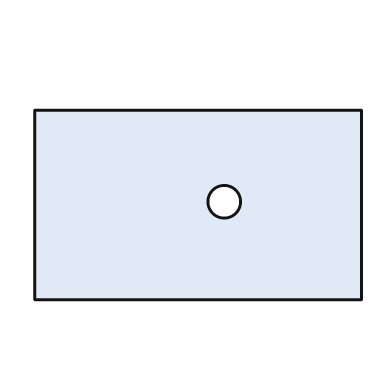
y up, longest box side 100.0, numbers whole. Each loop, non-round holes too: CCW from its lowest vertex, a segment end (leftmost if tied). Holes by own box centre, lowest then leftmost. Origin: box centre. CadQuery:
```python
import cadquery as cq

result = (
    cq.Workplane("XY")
    .moveTo(-50.0, -29.0)
    .lineTo(50.0, -29.0)
    .lineTo(50.0, 29.0)
    .lineTo(-50.0, 29.0)
    .close()
    .moveTo(8.0, 1.0)
    .circle(5.0)
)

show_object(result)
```